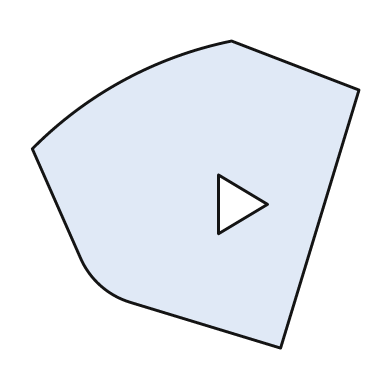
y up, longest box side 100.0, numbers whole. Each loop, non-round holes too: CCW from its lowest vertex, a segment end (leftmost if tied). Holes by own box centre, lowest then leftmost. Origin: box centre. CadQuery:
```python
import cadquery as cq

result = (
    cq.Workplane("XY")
    .moveTo(26.0, -47.0)
    .lineTo(50.0, 32.0)
    .lineTo(11.0, 47.0)
    .threePointArc((-22.0, 35.0), (-50.0, 14.0))
    .lineTo(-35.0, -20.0)
    .threePointArc((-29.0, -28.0), (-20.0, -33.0))
    .close()
    .moveTo(7.0, -12.0)
    .lineTo(22.0, -3.0)
    .lineTo(7.0, 6.0)
    .close()
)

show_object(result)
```